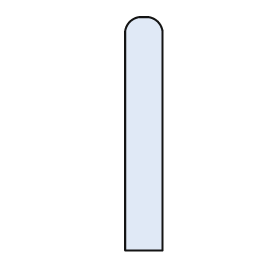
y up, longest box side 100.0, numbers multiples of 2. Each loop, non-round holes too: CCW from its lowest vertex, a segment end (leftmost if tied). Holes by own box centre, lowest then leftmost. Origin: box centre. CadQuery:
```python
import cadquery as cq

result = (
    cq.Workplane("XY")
    .moveTo(-8.0, -50.0)
    .lineTo(8.0, -50.0)
    .lineTo(8.0, 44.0)
    .threePointArc((6.0, 48.0), (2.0, 50.0))
    .lineTo(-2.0, 50.0)
    .threePointArc((-6.0, 48.0), (-8.0, 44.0))
    .close()
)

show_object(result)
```